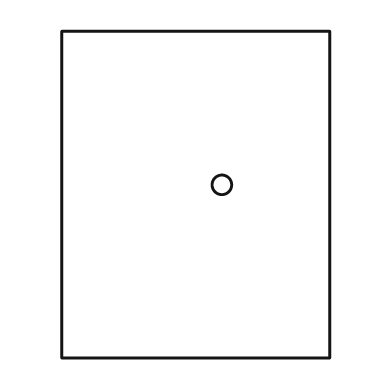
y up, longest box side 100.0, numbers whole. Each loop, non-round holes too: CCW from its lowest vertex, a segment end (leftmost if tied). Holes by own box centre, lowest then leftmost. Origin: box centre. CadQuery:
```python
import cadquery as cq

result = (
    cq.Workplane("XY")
    .moveTo(-41.0, -50.0)
    .lineTo(41.0, -50.0)
    .lineTo(41.0, 50.0)
    .lineTo(-41.0, 50.0)
    .close()
    .moveTo(8.0, 3.0)
    .circle(3.0)
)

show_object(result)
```